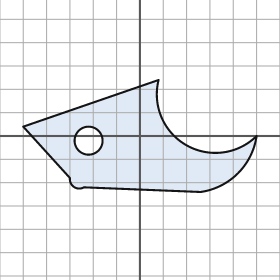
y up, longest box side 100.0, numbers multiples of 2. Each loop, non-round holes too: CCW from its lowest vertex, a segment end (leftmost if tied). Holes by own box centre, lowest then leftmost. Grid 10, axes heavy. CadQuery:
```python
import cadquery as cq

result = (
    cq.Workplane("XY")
    .moveTo(26.0, -24.0)
    .threePointArc((42.0, -16.0), (50.0, 0.0))
    .threePointArc((20.0, -4.0), (8.0, 24.0))
    .lineTo(-50.0, 4.0)
    .lineTo(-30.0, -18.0)
    .threePointArc((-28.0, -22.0), (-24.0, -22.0))
    .close()
    .moveTo(-22.0, -2.0)
    .circle(6.0)
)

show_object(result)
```